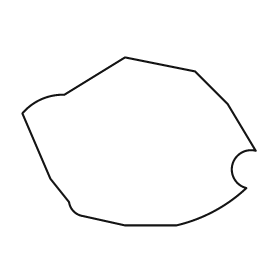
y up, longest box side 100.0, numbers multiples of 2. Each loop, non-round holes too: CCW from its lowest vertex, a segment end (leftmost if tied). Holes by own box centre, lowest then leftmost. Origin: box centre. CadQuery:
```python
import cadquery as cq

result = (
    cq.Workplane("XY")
    .moveTo(-6.0, -36.0)
    .lineTo(16.0, -36.0)
    .threePointArc((32.0, -30.0), (46.0, -20.0))
    .threePointArc((40.0, -10.0), (50.0, -4.0))
    .lineTo(38.0, 16.0)
    .lineTo(24.0, 30.0)
    .lineTo(-6.0, 36.0)
    .lineTo(-32.0, 20.0)
    .threePointArc((-42.0, 18.0), (-50.0, 12.0))
    .lineTo(-38.0, -16.0)
    .lineTo(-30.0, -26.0)
    .threePointArc((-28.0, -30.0), (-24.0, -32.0))
    .close()
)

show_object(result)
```